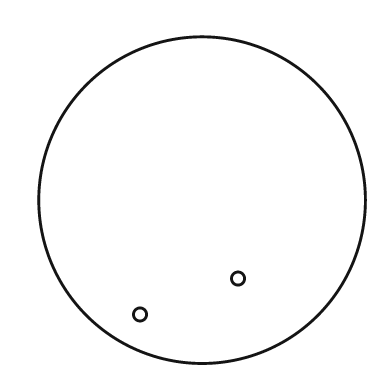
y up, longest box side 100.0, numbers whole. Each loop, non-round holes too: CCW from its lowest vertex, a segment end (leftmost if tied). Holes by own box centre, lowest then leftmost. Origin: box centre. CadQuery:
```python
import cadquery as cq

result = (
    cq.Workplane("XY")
    .moveTo(0.0, 0.0)
    .circle(50.0)
    .moveTo(-19.0, -35.0)
    .circle(2.0)
    .moveTo(11.0, -24.0)
    .circle(2.0)
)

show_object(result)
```